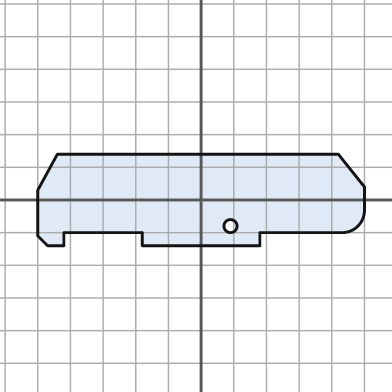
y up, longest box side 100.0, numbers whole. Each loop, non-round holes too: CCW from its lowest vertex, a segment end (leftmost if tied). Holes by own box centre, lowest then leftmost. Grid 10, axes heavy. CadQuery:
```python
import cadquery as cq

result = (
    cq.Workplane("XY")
    .moveTo(-47.0, -14.0)
    .lineTo(-42.0, -14.0)
    .lineTo(-42.0, -10.0)
    .lineTo(-18.0, -10.0)
    .lineTo(-18.0, -14.0)
    .lineTo(18.0, -14.0)
    .lineTo(18.0, -10.0)
    .lineTo(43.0, -10.0)
    .threePointArc((48.0, -8.0), (50.0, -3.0))
    .lineTo(50.0, 4.0)
    .lineTo(42.0, 14.0)
    .lineTo(-44.0, 14.0)
    .lineTo(-50.0, 3.0)
    .lineTo(-50.0, -11.0)
    .close()
    .moveTo(9.0, -8.0)
    .circle(2.0)
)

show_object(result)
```